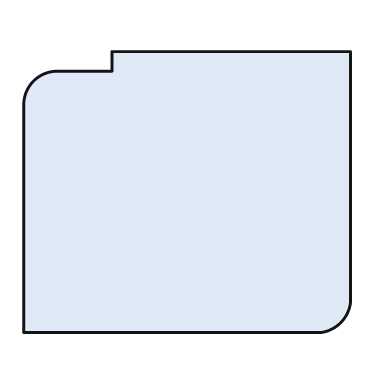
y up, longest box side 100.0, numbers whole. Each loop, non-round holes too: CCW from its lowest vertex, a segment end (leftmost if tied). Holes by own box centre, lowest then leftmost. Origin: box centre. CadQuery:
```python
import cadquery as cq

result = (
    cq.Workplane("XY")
    .moveTo(-50.0, -43.0)
    .lineTo(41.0, -43.0)
    .threePointArc((47.0, -40.0), (50.0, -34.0))
    .lineTo(50.0, 43.0)
    .lineTo(-23.0, 43.0)
    .lineTo(-23.0, 37.0)
    .lineTo(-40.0, 37.0)
    .threePointArc((-47.0, 34.0), (-50.0, 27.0))
    .close()
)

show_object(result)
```